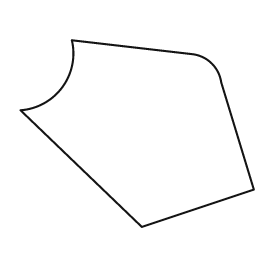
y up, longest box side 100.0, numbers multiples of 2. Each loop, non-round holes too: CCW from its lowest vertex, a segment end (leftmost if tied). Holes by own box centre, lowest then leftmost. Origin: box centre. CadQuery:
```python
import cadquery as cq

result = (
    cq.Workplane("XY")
    .moveTo(2.0, -40.0)
    .lineTo(50.0, -24.0)
    .lineTo(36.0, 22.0)
    .threePointArc((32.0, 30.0), (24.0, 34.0))
    .lineTo(-28.0, 40.0)
    .threePointArc((-32.0, 20.0), (-50.0, 10.0))
    .close()
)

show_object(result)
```